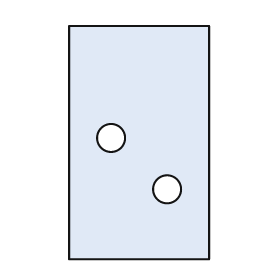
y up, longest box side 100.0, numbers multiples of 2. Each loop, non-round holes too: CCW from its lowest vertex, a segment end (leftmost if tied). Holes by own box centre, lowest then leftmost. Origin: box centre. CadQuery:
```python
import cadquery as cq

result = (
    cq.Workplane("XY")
    .moveTo(-30.0, -50.0)
    .lineTo(30.0, -50.0)
    .lineTo(30.0, 50.0)
    .lineTo(-30.0, 50.0)
    .close()
    .moveTo(12.0, -20.0)
    .circle(6.0)
    .moveTo(-12.0, 2.0)
    .circle(6.0)
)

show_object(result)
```